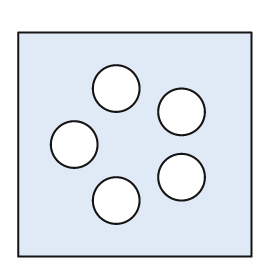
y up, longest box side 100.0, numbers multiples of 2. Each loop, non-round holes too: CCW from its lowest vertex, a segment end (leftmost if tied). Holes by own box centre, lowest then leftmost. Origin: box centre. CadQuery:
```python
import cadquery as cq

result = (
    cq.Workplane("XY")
    .moveTo(-50.0, -48.0)
    .lineTo(50.0, -48.0)
    .lineTo(50.0, 48.0)
    .lineTo(-50.0, 48.0)
    .close()
    .moveTo(-8.0, -24.0)
    .circle(10.0)
    .moveTo(20.0, -14.0)
    .circle(10.0)
    .moveTo(-26.0, 0.0)
    .circle(10.0)
    .moveTo(20.0, 14.0)
    .circle(10.0)
    .moveTo(-8.0, 24.0)
    .circle(10.0)
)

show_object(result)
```